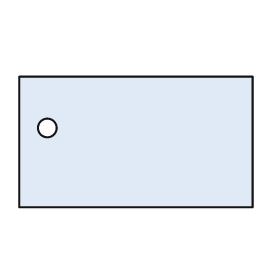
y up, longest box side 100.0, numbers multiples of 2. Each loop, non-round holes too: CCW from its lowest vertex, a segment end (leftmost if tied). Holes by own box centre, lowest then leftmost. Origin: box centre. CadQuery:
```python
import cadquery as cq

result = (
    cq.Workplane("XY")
    .moveTo(-50.0, -28.0)
    .lineTo(50.0, -28.0)
    .lineTo(50.0, 28.0)
    .lineTo(-50.0, 28.0)
    .close()
    .moveTo(-38.0, 6.0)
    .circle(4.0)
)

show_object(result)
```